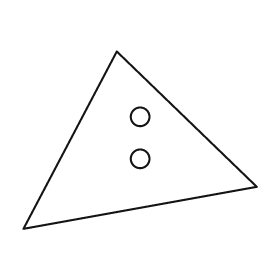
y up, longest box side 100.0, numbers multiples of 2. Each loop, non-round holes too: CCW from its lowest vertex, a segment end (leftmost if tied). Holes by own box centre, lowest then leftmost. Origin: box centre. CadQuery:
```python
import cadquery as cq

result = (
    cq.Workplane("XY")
    .moveTo(-50.0, -38.0)
    .lineTo(50.0, -20.0)
    .lineTo(-10.0, 38.0)
    .close()
    .moveTo(0.0, -8.0)
    .circle(4.0)
    .moveTo(0.0, 10.0)
    .circle(4.0)
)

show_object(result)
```